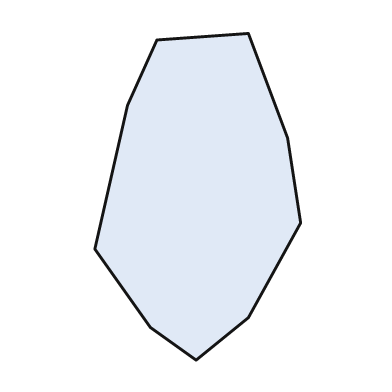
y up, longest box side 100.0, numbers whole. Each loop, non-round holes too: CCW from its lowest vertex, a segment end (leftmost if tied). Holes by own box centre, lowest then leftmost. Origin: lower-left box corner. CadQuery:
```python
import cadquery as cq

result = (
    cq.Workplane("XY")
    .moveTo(31.0, 0.0)
    .lineTo(47.0, 13.0)
    .lineTo(63.0, 42.0)
    .lineTo(59.0, 68.0)
    .lineTo(47.0, 100.0)
    .lineTo(19.0, 98.0)
    .lineTo(10.0, 78.0)
    .lineTo(0.0, 34.0)
    .lineTo(17.0, 10.0)
    .close()
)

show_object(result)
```